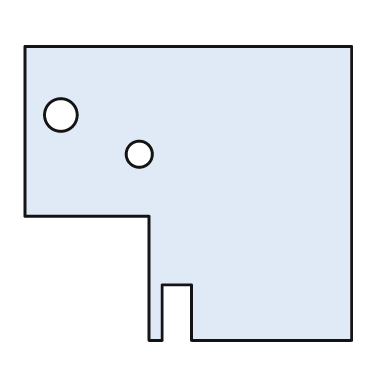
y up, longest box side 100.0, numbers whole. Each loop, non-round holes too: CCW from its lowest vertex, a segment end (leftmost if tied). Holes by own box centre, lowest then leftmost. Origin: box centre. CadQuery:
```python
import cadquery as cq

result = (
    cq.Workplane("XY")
    .moveTo(-12.0, -45.0)
    .lineTo(-8.0, -45.0)
    .lineTo(-8.0, -28.0)
    .lineTo(1.0, -28.0)
    .lineTo(1.0, -45.0)
    .lineTo(50.0, -45.0)
    .lineTo(50.0, 45.0)
    .lineTo(-50.0, 45.0)
    .lineTo(-50.0, -7.0)
    .lineTo(-12.0, -7.0)
    .close()
    .moveTo(-15.0, 12.0)
    .circle(4.0)
    .moveTo(-39.0, 24.0)
    .circle(5.0)
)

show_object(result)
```